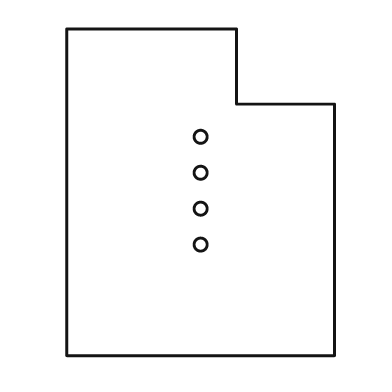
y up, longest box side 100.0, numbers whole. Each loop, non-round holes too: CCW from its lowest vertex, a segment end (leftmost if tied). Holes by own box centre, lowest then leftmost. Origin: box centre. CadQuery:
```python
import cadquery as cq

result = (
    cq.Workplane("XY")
    .moveTo(-41.0, -50.0)
    .lineTo(41.0, -50.0)
    .lineTo(41.0, 27.0)
    .lineTo(11.0, 27.0)
    .lineTo(11.0, 50.0)
    .lineTo(-41.0, 50.0)
    .close()
    .moveTo(0.0, -16.0)
    .circle(2.0)
    .moveTo(0.0, -5.0)
    .circle(2.0)
    .moveTo(0.0, 6.0)
    .circle(2.0)
    .moveTo(0.0, 17.0)
    .circle(2.0)
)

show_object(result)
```